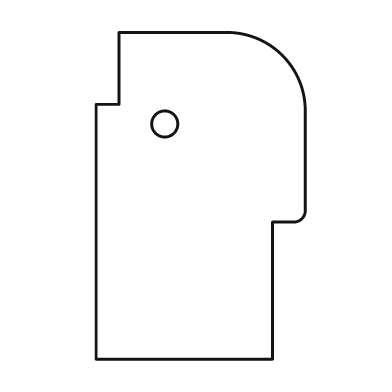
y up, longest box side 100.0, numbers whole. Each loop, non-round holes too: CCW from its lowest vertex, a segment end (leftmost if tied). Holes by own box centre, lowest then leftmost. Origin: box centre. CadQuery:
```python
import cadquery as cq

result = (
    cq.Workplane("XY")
    .moveTo(-32.0, -50.0)
    .lineTo(22.0, -50.0)
    .lineTo(22.0, -8.0)
    .lineTo(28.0, -8.0)
    .threePointArc((31.0, -7.0), (32.0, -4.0))
    .lineTo(32.0, 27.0)
    .threePointArc((25.0, 43.0), (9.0, 50.0))
    .lineTo(-25.0, 50.0)
    .lineTo(-25.0, 28.0)
    .lineTo(-32.0, 28.0)
    .close()
    .moveTo(-11.0, 22.0)
    .circle(4.0)
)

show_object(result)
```